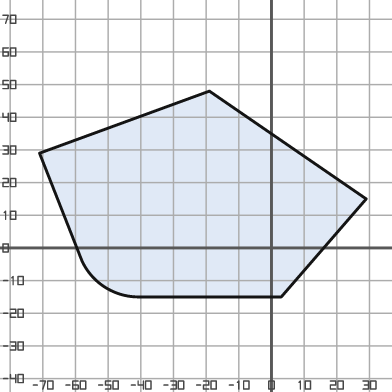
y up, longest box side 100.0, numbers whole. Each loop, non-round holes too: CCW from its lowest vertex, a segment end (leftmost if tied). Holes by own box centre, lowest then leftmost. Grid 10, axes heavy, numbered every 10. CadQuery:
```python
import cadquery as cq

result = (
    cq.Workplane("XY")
    .moveTo(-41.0, -15.0)
    .lineTo(3.0, -15.0)
    .lineTo(29.0, 15.0)
    .lineTo(-19.0, 48.0)
    .lineTo(-71.0, 29.0)
    .lineTo(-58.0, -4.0)
    .threePointArc((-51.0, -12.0), (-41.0, -15.0))
    .close()
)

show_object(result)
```